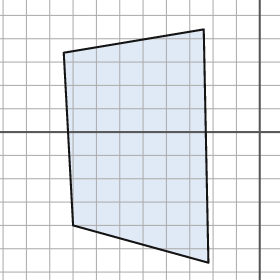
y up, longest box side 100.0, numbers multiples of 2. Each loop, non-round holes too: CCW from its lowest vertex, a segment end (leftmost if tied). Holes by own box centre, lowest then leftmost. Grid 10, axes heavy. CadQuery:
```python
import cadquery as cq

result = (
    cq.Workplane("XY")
    .moveTo(-22.0, -56.0)
    .lineTo(-24.0, 44.0)
    .lineTo(-84.0, 34.0)
    .lineTo(-80.0, -40.0)
    .close()
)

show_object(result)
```